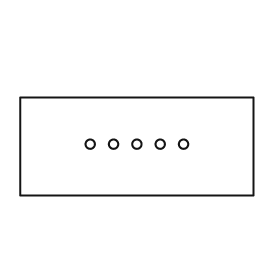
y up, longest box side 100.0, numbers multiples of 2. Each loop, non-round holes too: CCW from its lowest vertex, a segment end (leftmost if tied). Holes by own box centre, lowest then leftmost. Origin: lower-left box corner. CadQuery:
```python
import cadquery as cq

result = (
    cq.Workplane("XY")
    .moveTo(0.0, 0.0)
    .lineTo(100.0, 0.0)
    .lineTo(100.0, 42.0)
    .lineTo(0.0, 42.0)
    .close()
    .moveTo(30.0, 22.0)
    .circle(2.0)
    .moveTo(40.0, 22.0)
    .circle(2.0)
    .moveTo(50.0, 22.0)
    .circle(2.0)
    .moveTo(60.0, 22.0)
    .circle(2.0)
    .moveTo(70.0, 22.0)
    .circle(2.0)
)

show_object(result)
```